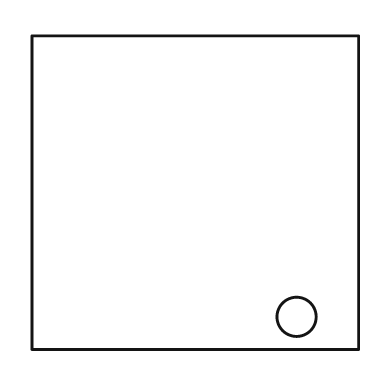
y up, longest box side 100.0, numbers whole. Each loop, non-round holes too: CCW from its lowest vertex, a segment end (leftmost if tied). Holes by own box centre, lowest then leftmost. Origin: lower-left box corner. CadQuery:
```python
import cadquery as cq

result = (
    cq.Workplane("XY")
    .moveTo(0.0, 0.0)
    .lineTo(100.0, 0.0)
    .lineTo(100.0, 96.0)
    .lineTo(0.0, 96.0)
    .close()
    .moveTo(81.0, 10.0)
    .circle(6.0)
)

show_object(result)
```